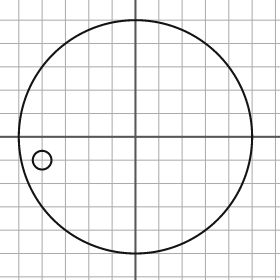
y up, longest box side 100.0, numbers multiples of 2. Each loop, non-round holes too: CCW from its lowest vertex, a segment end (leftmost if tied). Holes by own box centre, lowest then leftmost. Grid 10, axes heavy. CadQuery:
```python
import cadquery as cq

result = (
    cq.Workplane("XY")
    .moveTo(0.0, 0.0)
    .circle(50.0)
    .moveTo(-40.0, -10.0)
    .circle(4.0)
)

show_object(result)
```